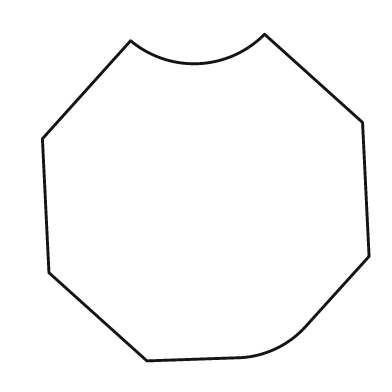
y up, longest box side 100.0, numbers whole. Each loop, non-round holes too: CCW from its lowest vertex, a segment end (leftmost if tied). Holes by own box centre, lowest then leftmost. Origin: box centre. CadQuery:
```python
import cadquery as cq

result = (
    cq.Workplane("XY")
    .moveTo(-18.0, -50.0)
    .lineTo(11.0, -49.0)
    .threePointArc((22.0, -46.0), (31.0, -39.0))
    .lineTo(50.0, -18.0)
    .lineTo(48.0, 23.0)
    .lineTo(18.0, 50.0)
    .threePointArc((-2.0, 41.0), (-23.0, 48.0))
    .lineTo(-50.0, 18.0)
    .lineTo(-48.0, -23.0)
    .close()
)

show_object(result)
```